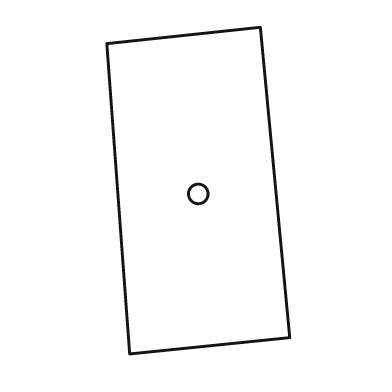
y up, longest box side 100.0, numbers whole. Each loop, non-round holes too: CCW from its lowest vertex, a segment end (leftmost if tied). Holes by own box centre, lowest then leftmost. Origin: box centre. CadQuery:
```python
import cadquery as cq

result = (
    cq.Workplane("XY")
    .moveTo(-21.0, -50.0)
    .lineTo(28.0, -45.0)
    .lineTo(19.0, 50.0)
    .lineTo(-28.0, 45.0)
    .close()
    .moveTo(0.0, -1.0)
    .circle(3.0)
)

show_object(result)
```